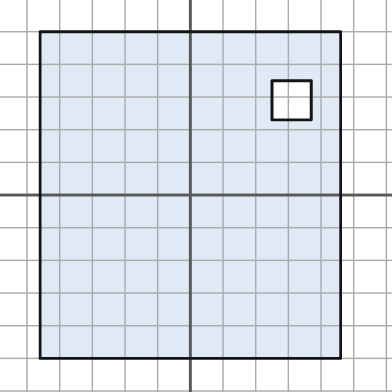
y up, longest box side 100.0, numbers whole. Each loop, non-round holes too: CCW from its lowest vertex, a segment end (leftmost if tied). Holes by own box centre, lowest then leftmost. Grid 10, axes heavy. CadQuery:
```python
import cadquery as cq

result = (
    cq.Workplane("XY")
    .moveTo(-46.0, -50.0)
    .lineTo(46.0, -50.0)
    .lineTo(46.0, 50.0)
    .lineTo(-46.0, 50.0)
    .close()
    .moveTo(25.0, 23.0)
    .lineTo(37.0, 23.0)
    .lineTo(37.0, 35.0)
    .lineTo(25.0, 35.0)
    .close()
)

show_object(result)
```